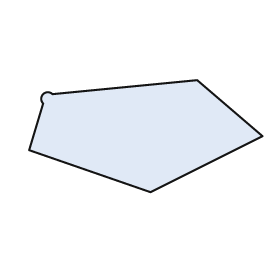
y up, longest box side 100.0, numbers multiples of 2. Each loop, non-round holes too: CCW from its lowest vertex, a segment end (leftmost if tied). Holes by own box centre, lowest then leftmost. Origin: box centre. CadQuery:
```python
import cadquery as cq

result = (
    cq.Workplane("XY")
    .moveTo(2.0, -24.0)
    .lineTo(50.0, 0.0)
    .lineTo(22.0, 24.0)
    .lineTo(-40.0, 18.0)
    .threePointArc((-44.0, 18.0), (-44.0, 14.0))
    .lineTo(-50.0, -6.0)
    .close()
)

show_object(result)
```